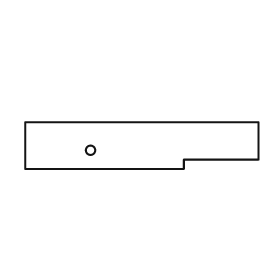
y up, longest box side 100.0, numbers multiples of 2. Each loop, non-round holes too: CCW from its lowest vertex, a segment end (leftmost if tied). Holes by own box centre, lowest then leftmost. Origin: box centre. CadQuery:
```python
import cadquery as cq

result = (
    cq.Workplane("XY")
    .moveTo(-50.0, -10.0)
    .lineTo(18.0, -10.0)
    .lineTo(18.0, -6.0)
    .lineTo(50.0, -6.0)
    .lineTo(50.0, 10.0)
    .lineTo(-50.0, 10.0)
    .close()
    .moveTo(-22.0, -2.0)
    .circle(2.0)
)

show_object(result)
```